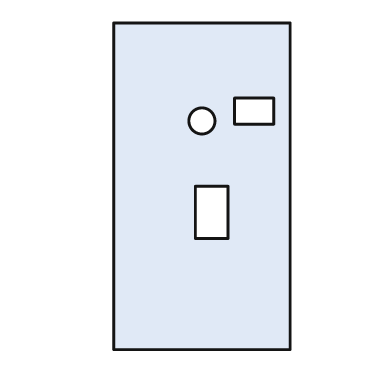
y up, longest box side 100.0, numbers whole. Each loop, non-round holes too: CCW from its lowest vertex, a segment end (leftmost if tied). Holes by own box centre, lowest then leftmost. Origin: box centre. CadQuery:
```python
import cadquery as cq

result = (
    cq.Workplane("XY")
    .moveTo(-27.0, -50.0)
    .lineTo(27.0, -50.0)
    .lineTo(27.0, 50.0)
    .lineTo(-27.0, 50.0)
    .close()
    .moveTo(-2.0, -16.0)
    .lineTo(8.0, -16.0)
    .lineTo(8.0, 0.0)
    .lineTo(-2.0, 0.0)
    .close()
    .moveTo(0.0, 20.0)
    .circle(4.0)
    .moveTo(10.0, 19.0)
    .lineTo(22.0, 19.0)
    .lineTo(22.0, 27.0)
    .lineTo(10.0, 27.0)
    .close()
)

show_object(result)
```